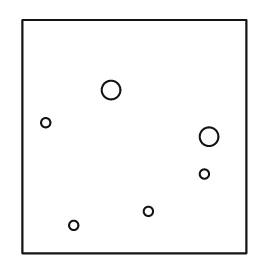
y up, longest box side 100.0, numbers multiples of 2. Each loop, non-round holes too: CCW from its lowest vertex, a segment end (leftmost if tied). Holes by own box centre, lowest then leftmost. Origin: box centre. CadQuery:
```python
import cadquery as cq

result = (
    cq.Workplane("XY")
    .moveTo(-48.0, -50.0)
    .lineTo(48.0, -50.0)
    .lineTo(48.0, 50.0)
    .lineTo(-48.0, 50.0)
    .close()
    .moveTo(-26.0, -38.0)
    .circle(2.0)
    .moveTo(6.0, -32.0)
    .circle(2.0)
    .moveTo(30.0, -16.0)
    .circle(2.0)
    .moveTo(32.0, 0.0)
    .circle(4.0)
    .moveTo(-38.0, 6.0)
    .circle(2.0)
    .moveTo(-10.0, 20.0)
    .circle(4.0)
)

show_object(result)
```